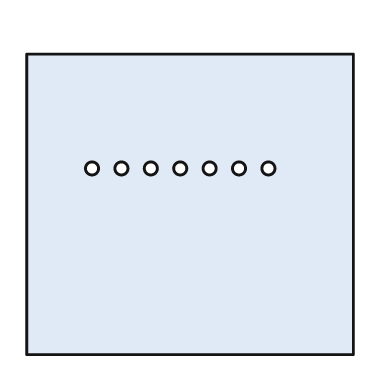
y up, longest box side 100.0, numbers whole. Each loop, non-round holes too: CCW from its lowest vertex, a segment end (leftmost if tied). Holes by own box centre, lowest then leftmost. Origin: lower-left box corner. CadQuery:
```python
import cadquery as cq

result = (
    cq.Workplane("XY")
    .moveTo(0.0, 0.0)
    .lineTo(100.0, 0.0)
    .lineTo(100.0, 92.0)
    .lineTo(0.0, 92.0)
    .close()
    .moveTo(20.0, 57.0)
    .circle(2.0)
    .moveTo(29.0, 57.0)
    .circle(2.0)
    .moveTo(38.0, 57.0)
    .circle(2.0)
    .moveTo(47.0, 57.0)
    .circle(2.0)
    .moveTo(56.0, 57.0)
    .circle(2.0)
    .moveTo(65.0, 57.0)
    .circle(2.0)
    .moveTo(74.0, 57.0)
    .circle(2.0)
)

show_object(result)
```